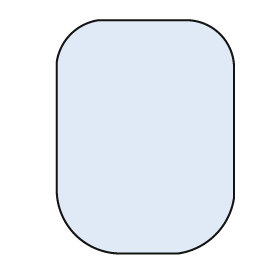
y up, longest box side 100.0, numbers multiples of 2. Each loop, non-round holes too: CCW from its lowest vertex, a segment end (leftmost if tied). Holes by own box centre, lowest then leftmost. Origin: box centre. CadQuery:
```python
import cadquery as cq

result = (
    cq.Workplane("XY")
    .moveTo(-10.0, -50.0)
    .lineTo(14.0, -50.0)
    .threePointArc((30.0, -42.0), (38.0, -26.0))
    .lineTo(38.0, 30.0)
    .threePointArc((32.0, 44.0), (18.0, 50.0))
    .lineTo(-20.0, 50.0)
    .threePointArc((-32.0, 44.0), (-38.0, 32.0))
    .lineTo(-38.0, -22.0)
    .threePointArc((-30.0, -42.0), (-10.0, -50.0))
    .close()
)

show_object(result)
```